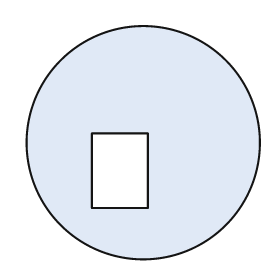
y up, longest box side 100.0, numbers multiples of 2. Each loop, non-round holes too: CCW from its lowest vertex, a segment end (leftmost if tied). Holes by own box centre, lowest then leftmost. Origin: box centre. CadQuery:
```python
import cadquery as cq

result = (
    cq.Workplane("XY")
    .moveTo(0.0, 0.0)
    .circle(50.0)
    .moveTo(-22.0, -28.0)
    .lineTo(2.0, -28.0)
    .lineTo(2.0, 4.0)
    .lineTo(-22.0, 4.0)
    .close()
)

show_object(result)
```